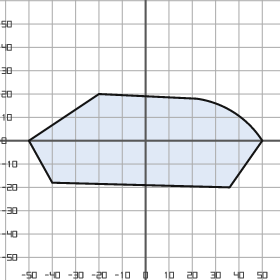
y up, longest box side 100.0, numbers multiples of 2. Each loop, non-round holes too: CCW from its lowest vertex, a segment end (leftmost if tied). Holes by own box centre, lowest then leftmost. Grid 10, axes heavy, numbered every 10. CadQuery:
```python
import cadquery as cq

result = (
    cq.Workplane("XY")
    .moveTo(36.0, -20.0)
    .lineTo(50.0, 0.0)
    .threePointArc((38.0, 12.0), (22.0, 18.0))
    .lineTo(-20.0, 20.0)
    .lineTo(-50.0, 0.0)
    .lineTo(-40.0, -18.0)
    .close()
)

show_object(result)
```